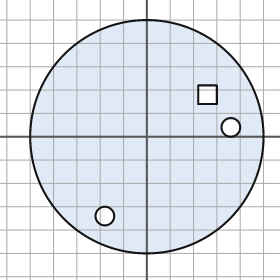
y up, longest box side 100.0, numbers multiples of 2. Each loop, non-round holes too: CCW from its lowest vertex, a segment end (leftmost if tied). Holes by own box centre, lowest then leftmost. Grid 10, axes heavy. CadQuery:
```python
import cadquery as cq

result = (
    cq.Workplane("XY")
    .moveTo(0.0, 0.0)
    .circle(50.0)
    .moveTo(-18.0, -34.0)
    .circle(4.0)
    .moveTo(36.0, 4.0)
    .circle(4.0)
    .moveTo(22.0, 14.0)
    .lineTo(30.0, 14.0)
    .lineTo(30.0, 22.0)
    .lineTo(22.0, 22.0)
    .close()
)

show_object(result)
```